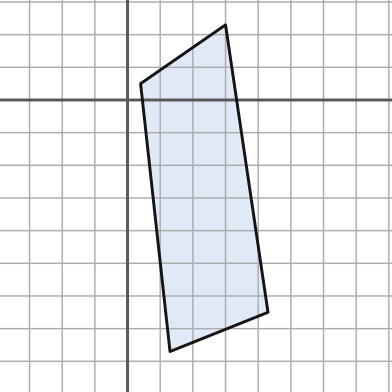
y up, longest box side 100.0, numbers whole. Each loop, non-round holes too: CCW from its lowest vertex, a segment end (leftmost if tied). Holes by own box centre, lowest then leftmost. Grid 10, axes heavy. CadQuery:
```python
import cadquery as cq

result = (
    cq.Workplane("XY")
    .moveTo(13.0, -77.0)
    .lineTo(43.0, -65.0)
    .lineTo(30.0, 23.0)
    .lineTo(4.0, 5.0)
    .close()
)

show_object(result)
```